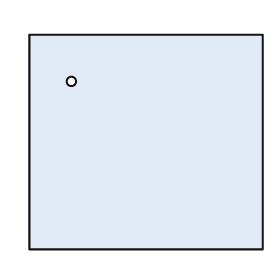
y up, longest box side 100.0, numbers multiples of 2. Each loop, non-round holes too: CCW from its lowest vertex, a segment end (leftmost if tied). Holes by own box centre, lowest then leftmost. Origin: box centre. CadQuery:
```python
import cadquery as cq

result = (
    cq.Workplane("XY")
    .moveTo(-50.0, -46.0)
    .lineTo(50.0, -46.0)
    .lineTo(50.0, 46.0)
    .lineTo(-50.0, 46.0)
    .close()
    .moveTo(-32.0, 26.0)
    .circle(2.0)
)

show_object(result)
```